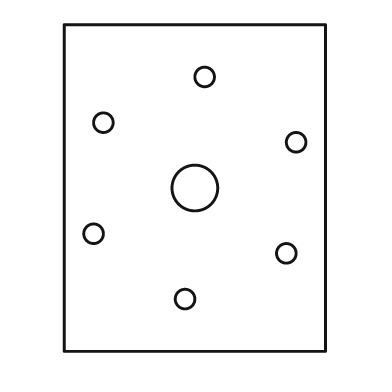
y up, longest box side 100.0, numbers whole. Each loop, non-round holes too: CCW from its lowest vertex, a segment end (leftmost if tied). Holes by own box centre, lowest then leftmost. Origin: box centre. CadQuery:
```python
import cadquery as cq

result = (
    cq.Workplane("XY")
    .moveTo(-40.0, -50.0)
    .lineTo(40.0, -50.0)
    .lineTo(40.0, 50.0)
    .lineTo(-40.0, 50.0)
    .close()
    .moveTo(-3.0, -34.0)
    .circle(3.0)
    .moveTo(28.0, -20.0)
    .circle(3.0)
    .moveTo(-31.0, -14.0)
    .circle(3.0)
    .moveTo(0.0, 0.0)
    .circle(7.0)
    .moveTo(31.0, 14.0)
    .circle(3.0)
    .moveTo(-28.0, 20.0)
    .circle(3.0)
    .moveTo(3.0, 34.0)
    .circle(3.0)
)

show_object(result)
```